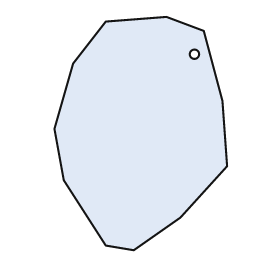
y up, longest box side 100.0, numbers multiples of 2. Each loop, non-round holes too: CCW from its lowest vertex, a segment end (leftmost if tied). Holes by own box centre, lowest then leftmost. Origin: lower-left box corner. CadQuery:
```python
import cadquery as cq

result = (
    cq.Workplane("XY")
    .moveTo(34.0, 0.0)
    .lineTo(54.0, 14.0)
    .lineTo(74.0, 36.0)
    .lineTo(72.0, 64.0)
    .lineTo(64.0, 94.0)
    .lineTo(48.0, 100.0)
    .lineTo(22.0, 98.0)
    .lineTo(8.0, 80.0)
    .lineTo(0.0, 52.0)
    .lineTo(4.0, 30.0)
    .lineTo(22.0, 2.0)
    .close()
    .moveTo(60.0, 84.0)
    .circle(2.0)
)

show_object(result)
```